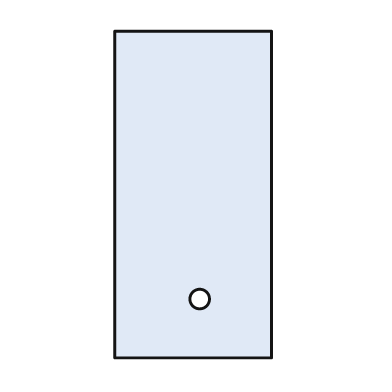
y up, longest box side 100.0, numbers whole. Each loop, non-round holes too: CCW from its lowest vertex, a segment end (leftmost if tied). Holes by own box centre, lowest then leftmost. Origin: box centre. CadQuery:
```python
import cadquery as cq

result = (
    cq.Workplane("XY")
    .moveTo(-24.0, -50.0)
    .lineTo(24.0, -50.0)
    .lineTo(24.0, 50.0)
    .lineTo(-24.0, 50.0)
    .close()
    .moveTo(2.0, -32.0)
    .circle(3.0)
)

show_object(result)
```